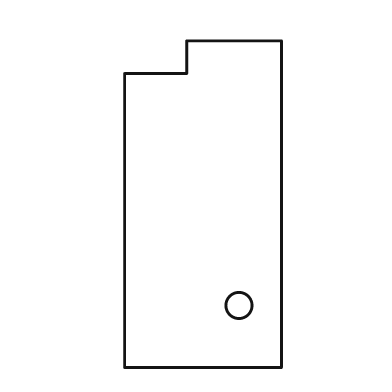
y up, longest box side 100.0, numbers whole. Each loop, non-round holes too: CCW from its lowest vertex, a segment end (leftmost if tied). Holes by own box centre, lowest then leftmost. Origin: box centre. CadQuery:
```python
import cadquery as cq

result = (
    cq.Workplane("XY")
    .moveTo(-24.0, -50.0)
    .lineTo(24.0, -50.0)
    .lineTo(24.0, 50.0)
    .lineTo(-5.0, 50.0)
    .lineTo(-5.0, 40.0)
    .lineTo(-24.0, 40.0)
    .close()
    .moveTo(11.0, -31.0)
    .circle(4.0)
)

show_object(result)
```